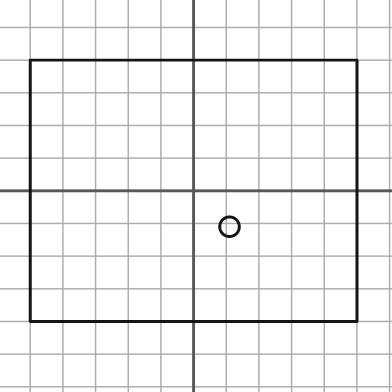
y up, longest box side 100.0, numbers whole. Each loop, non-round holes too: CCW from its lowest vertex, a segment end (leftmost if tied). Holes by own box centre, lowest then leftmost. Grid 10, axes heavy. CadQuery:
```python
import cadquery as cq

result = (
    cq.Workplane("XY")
    .moveTo(-50.0, -40.0)
    .lineTo(50.0, -40.0)
    .lineTo(50.0, 40.0)
    .lineTo(-50.0, 40.0)
    .close()
    .moveTo(11.0, -11.0)
    .circle(3.0)
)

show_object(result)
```